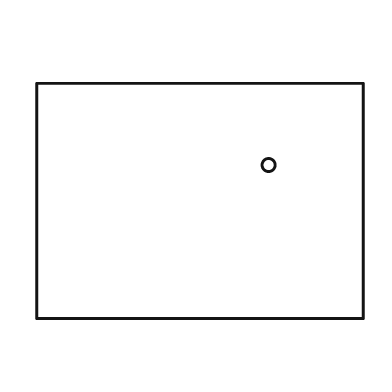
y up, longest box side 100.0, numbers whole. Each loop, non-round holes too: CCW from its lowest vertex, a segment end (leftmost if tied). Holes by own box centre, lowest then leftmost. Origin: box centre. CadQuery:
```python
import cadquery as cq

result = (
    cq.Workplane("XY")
    .moveTo(-50.0, -36.0)
    .lineTo(50.0, -36.0)
    .lineTo(50.0, 36.0)
    .lineTo(-50.0, 36.0)
    .close()
    .moveTo(21.0, 11.0)
    .circle(2.0)
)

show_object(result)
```